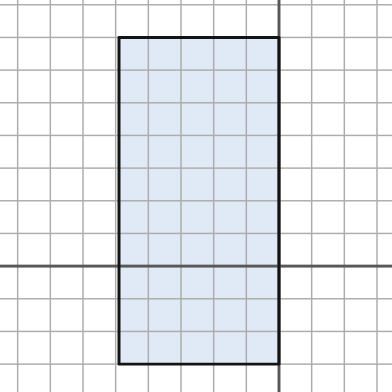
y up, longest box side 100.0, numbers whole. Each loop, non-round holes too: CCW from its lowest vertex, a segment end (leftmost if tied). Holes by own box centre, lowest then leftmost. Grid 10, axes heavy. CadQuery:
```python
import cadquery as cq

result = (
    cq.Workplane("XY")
    .moveTo(-49.0, -30.0)
    .lineTo(0.0, -30.0)
    .lineTo(0.0, 70.0)
    .lineTo(-49.0, 70.0)
    .close()
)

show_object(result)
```